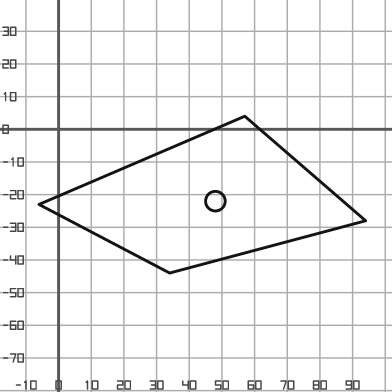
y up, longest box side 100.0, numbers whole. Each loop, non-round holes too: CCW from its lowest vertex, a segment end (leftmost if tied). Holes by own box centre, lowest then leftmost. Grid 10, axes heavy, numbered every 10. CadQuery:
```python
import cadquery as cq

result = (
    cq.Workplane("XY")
    .moveTo(34.0, -44.0)
    .lineTo(94.0, -28.0)
    .lineTo(57.0, 4.0)
    .lineTo(-6.0, -23.0)
    .close()
    .moveTo(48.0, -22.0)
    .circle(3.0)
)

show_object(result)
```